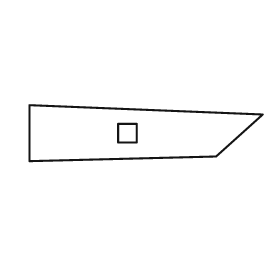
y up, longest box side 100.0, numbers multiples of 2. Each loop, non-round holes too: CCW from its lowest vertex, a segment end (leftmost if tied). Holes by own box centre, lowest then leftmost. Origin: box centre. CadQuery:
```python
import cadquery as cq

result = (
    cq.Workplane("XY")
    .moveTo(-50.0, -12.0)
    .lineTo(30.0, -10.0)
    .lineTo(50.0, 8.0)
    .lineTo(-50.0, 12.0)
    .close()
    .moveTo(-12.0, -4.0)
    .lineTo(-4.0, -4.0)
    .lineTo(-4.0, 4.0)
    .lineTo(-12.0, 4.0)
    .close()
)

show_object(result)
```